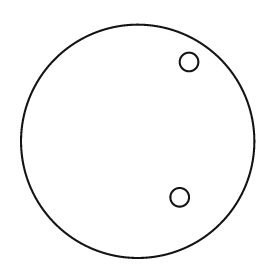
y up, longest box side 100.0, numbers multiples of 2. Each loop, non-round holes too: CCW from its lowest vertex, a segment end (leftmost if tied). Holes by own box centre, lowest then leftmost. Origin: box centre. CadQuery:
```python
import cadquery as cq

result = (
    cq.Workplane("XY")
    .moveTo(0.0, 0.0)
    .circle(50.0)
    .moveTo(18.0, -24.0)
    .circle(4.0)
    .moveTo(22.0, 34.0)
    .circle(4.0)
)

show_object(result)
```